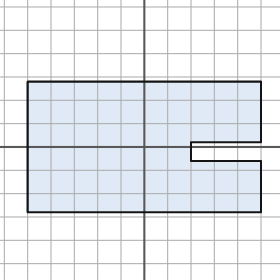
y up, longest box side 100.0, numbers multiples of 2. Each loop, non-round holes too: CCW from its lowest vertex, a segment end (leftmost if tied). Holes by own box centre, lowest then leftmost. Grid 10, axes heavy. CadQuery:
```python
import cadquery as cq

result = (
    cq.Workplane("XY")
    .moveTo(-50.0, -28.0)
    .lineTo(50.0, -28.0)
    .lineTo(50.0, -6.0)
    .lineTo(20.0, -6.0)
    .lineTo(20.0, 2.0)
    .lineTo(50.0, 2.0)
    .lineTo(50.0, 28.0)
    .lineTo(-50.0, 28.0)
    .close()
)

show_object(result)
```